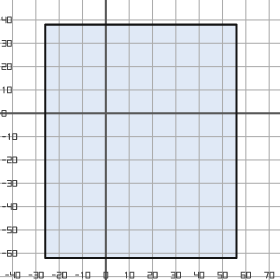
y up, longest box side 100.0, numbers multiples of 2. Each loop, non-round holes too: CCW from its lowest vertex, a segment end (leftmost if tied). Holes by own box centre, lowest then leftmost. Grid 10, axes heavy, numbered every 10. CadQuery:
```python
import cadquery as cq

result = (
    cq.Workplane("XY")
    .moveTo(-26.0, -62.0)
    .lineTo(56.0, -62.0)
    .lineTo(56.0, 38.0)
    .lineTo(-26.0, 38.0)
    .close()
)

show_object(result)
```